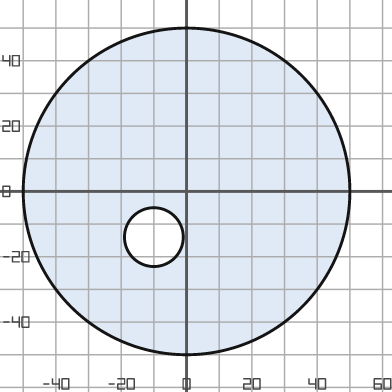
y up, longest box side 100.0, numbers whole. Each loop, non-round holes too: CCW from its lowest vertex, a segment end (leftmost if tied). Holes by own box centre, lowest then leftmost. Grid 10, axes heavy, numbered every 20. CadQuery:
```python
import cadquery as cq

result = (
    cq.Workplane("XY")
    .moveTo(0.0, 0.0)
    .circle(50.0)
    .moveTo(-10.0, -14.0)
    .circle(9.0)
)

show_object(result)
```